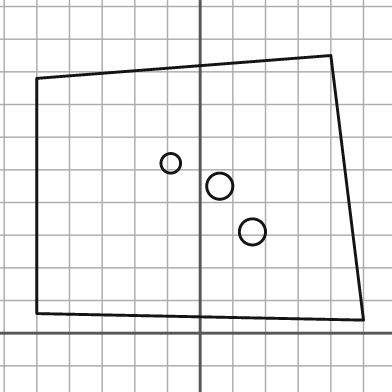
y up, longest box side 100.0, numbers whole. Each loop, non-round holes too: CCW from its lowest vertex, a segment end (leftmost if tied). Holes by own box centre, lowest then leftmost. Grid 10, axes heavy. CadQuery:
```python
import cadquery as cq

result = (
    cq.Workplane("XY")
    .moveTo(50.0, 4.0)
    .lineTo(40.0, 85.0)
    .lineTo(-50.0, 78.0)
    .lineTo(-50.0, 6.0)
    .close()
    .moveTo(16.0, 31.0)
    .circle(4.0)
    .moveTo(6.0, 45.0)
    .circle(4.0)
    .moveTo(-9.0, 52.0)
    .circle(3.0)
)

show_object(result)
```